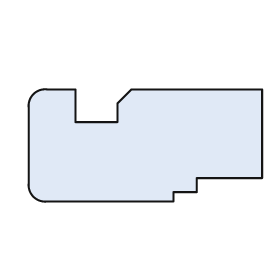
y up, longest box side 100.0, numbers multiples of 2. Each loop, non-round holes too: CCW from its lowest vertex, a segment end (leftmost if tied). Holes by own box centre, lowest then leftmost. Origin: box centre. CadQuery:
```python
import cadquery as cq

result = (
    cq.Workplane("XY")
    .moveTo(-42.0, -24.0)
    .lineTo(12.0, -24.0)
    .lineTo(12.0, -20.0)
    .lineTo(22.0, -20.0)
    .lineTo(22.0, -14.0)
    .lineTo(50.0, -14.0)
    .lineTo(50.0, 24.0)
    .lineTo(-6.0, 24.0)
    .lineTo(-12.0, 18.0)
    .lineTo(-12.0, 10.0)
    .lineTo(-30.0, 10.0)
    .lineTo(-30.0, 24.0)
    .lineTo(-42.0, 24.0)
    .threePointArc((-48.0, 22.0), (-50.0, 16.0))
    .lineTo(-50.0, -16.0)
    .threePointArc((-48.0, -22.0), (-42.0, -24.0))
    .close()
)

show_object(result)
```